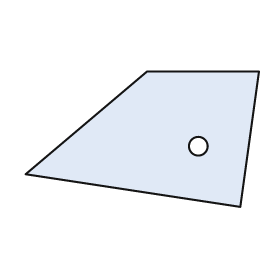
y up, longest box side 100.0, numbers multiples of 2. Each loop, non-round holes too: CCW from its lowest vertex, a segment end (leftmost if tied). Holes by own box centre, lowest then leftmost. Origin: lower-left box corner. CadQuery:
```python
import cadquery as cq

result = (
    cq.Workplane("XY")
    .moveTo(92.0, 0.0)
    .lineTo(100.0, 58.0)
    .lineTo(52.0, 58.0)
    .lineTo(0.0, 14.0)
    .close()
    .moveTo(74.0, 26.0)
    .circle(4.0)
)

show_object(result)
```